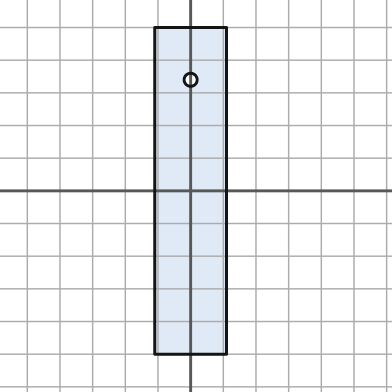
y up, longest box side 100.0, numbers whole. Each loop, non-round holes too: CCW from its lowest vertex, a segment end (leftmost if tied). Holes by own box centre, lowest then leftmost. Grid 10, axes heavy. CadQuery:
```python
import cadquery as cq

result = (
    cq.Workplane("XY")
    .moveTo(-11.0, -50.0)
    .lineTo(11.0, -50.0)
    .lineTo(11.0, 50.0)
    .lineTo(-11.0, 50.0)
    .close()
    .moveTo(0.0, 34.0)
    .circle(2.0)
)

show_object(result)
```